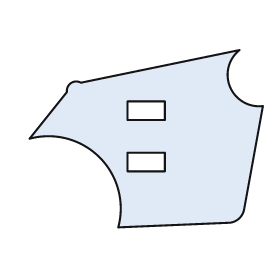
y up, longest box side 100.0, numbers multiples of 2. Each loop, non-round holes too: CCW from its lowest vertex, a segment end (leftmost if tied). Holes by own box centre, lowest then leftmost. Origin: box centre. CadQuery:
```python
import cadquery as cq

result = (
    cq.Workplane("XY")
    .moveTo(-12.0, -38.0)
    .lineTo(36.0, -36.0)
    .threePointArc((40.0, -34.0), (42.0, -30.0))
    .lineTo(50.0, 14.0)
    .threePointArc((36.0, 22.0), (40.0, 38.0))
    .lineTo(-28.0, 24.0)
    .threePointArc((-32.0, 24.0), (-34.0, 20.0))
    .lineTo(-50.0, 0.0)
    .threePointArc((-20.0, -8.0), (-12.0, -38.0))
    .close()
    .moveTo(-8.0, -14.0)
    .lineTo(8.0, -14.0)
    .lineTo(8.0, -6.0)
    .lineTo(-8.0, -6.0)
    .close()
    .moveTo(-8.0, 8.0)
    .lineTo(8.0, 8.0)
    .lineTo(8.0, 16.0)
    .lineTo(-8.0, 16.0)
    .close()
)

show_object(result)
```